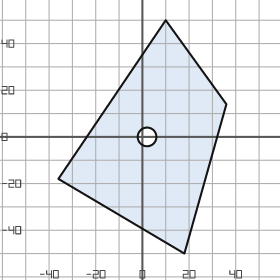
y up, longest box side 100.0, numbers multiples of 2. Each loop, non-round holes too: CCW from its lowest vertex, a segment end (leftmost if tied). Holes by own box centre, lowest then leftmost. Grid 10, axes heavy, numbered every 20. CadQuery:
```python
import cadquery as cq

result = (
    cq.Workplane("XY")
    .moveTo(18.0, -50.0)
    .lineTo(36.0, 14.0)
    .lineTo(10.0, 50.0)
    .lineTo(-36.0, -18.0)
    .close()
    .moveTo(2.0, 0.0)
    .circle(4.0)
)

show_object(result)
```